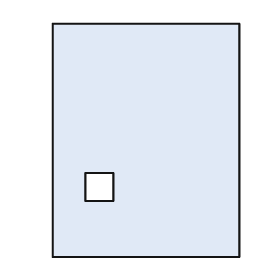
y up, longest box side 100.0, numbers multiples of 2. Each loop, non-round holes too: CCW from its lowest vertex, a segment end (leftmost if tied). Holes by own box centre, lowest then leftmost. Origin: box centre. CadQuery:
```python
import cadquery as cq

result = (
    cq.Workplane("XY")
    .moveTo(-40.0, -50.0)
    .lineTo(40.0, -50.0)
    .lineTo(40.0, 50.0)
    .lineTo(-40.0, 50.0)
    .close()
    .moveTo(-26.0, -26.0)
    .lineTo(-14.0, -26.0)
    .lineTo(-14.0, -14.0)
    .lineTo(-26.0, -14.0)
    .close()
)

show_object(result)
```